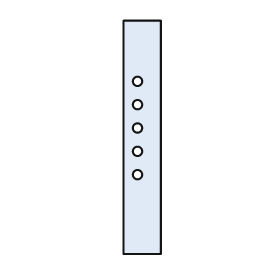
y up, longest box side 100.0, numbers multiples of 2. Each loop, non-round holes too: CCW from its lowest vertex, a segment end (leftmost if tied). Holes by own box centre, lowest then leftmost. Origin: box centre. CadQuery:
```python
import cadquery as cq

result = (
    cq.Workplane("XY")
    .moveTo(-8.0, -50.0)
    .lineTo(8.0, -50.0)
    .lineTo(8.0, 50.0)
    .lineTo(-8.0, 50.0)
    .close()
    .moveTo(-2.0, -16.0)
    .circle(2.0)
    .moveTo(-2.0, -6.0)
    .circle(2.0)
    .moveTo(-2.0, 4.0)
    .circle(2.0)
    .moveTo(-2.0, 14.0)
    .circle(2.0)
    .moveTo(-2.0, 24.0)
    .circle(2.0)
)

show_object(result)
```